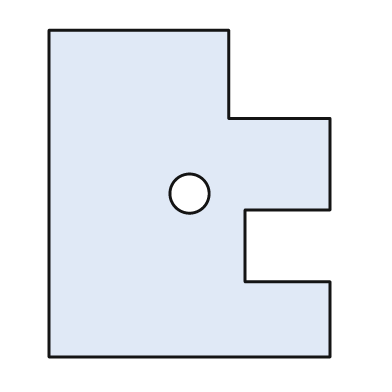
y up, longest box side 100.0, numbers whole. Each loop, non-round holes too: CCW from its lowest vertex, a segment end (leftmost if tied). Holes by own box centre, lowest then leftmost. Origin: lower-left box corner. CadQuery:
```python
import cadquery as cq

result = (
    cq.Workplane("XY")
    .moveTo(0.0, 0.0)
    .lineTo(86.0, 0.0)
    .lineTo(86.0, 23.0)
    .lineTo(60.0, 23.0)
    .lineTo(60.0, 45.0)
    .lineTo(86.0, 45.0)
    .lineTo(86.0, 73.0)
    .lineTo(55.0, 73.0)
    .lineTo(55.0, 100.0)
    .lineTo(0.0, 100.0)
    .close()
    .moveTo(43.0, 50.0)
    .circle(6.0)
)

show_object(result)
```